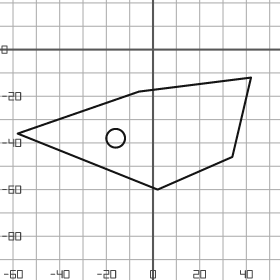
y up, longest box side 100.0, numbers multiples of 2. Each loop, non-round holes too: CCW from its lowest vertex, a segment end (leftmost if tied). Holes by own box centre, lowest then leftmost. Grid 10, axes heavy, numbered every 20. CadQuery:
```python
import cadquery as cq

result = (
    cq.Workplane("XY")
    .moveTo(2.0, -60.0)
    .lineTo(34.0, -46.0)
    .lineTo(42.0, -12.0)
    .lineTo(-6.0, -18.0)
    .lineTo(-58.0, -36.0)
    .close()
    .moveTo(-16.0, -38.0)
    .circle(4.0)
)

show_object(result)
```